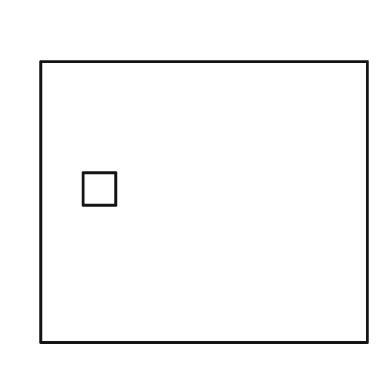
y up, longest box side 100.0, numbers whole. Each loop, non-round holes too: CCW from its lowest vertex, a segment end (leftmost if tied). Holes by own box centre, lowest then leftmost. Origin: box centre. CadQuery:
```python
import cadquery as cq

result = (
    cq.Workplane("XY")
    .moveTo(-50.0, -43.0)
    .lineTo(50.0, -43.0)
    .lineTo(50.0, 43.0)
    .lineTo(-50.0, 43.0)
    .close()
    .moveTo(-37.0, -1.0)
    .lineTo(-27.0, -1.0)
    .lineTo(-27.0, 9.0)
    .lineTo(-37.0, 9.0)
    .close()
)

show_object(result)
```